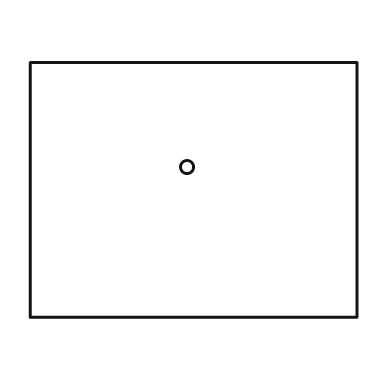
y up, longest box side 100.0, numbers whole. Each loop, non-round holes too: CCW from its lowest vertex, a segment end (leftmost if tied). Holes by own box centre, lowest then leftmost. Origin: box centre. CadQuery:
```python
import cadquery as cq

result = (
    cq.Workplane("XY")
    .moveTo(-50.0, -39.0)
    .lineTo(50.0, -39.0)
    .lineTo(50.0, 39.0)
    .lineTo(-50.0, 39.0)
    .close()
    .moveTo(-2.0, 7.0)
    .circle(2.0)
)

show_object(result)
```